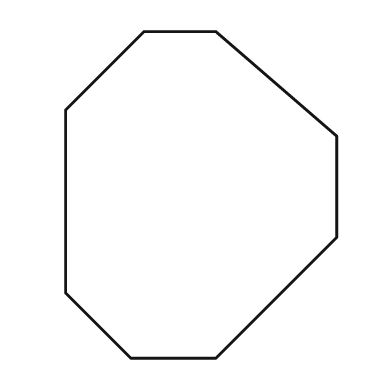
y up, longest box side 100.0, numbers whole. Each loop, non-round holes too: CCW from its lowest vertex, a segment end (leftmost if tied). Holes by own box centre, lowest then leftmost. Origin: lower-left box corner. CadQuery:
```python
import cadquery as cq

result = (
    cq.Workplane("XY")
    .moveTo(20.0, 0.0)
    .lineTo(46.0, 0.0)
    .lineTo(83.0, 37.0)
    .lineTo(83.0, 68.0)
    .lineTo(46.0, 100.0)
    .lineTo(24.0, 100.0)
    .lineTo(0.0, 76.0)
    .lineTo(0.0, 20.0)
    .close()
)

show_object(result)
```